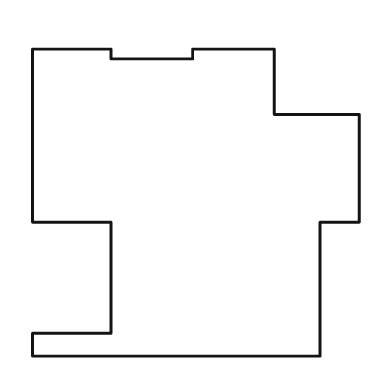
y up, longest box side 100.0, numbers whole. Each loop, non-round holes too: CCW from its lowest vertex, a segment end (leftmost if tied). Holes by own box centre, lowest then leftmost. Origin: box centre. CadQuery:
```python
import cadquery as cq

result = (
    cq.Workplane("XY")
    .moveTo(-50.0, -47.0)
    .lineTo(38.0, -47.0)
    .lineTo(38.0, -6.0)
    .lineTo(50.0, -6.0)
    .lineTo(50.0, 27.0)
    .lineTo(24.0, 27.0)
    .lineTo(24.0, 47.0)
    .lineTo(-1.0, 47.0)
    .lineTo(-1.0, 44.0)
    .lineTo(-26.0, 44.0)
    .lineTo(-26.0, 47.0)
    .lineTo(-50.0, 47.0)
    .lineTo(-50.0, -6.0)
    .lineTo(-26.0, -6.0)
    .lineTo(-26.0, -40.0)
    .lineTo(-50.0, -40.0)
    .close()
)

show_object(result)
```